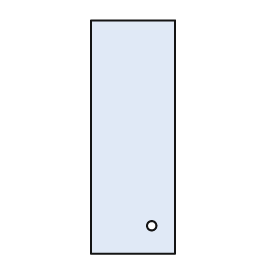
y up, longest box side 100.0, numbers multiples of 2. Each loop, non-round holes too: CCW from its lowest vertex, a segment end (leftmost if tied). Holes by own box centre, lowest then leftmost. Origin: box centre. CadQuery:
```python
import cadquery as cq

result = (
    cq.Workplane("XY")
    .moveTo(-18.0, -50.0)
    .lineTo(18.0, -50.0)
    .lineTo(18.0, 50.0)
    .lineTo(-18.0, 50.0)
    .close()
    .moveTo(8.0, -38.0)
    .circle(2.0)
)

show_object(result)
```